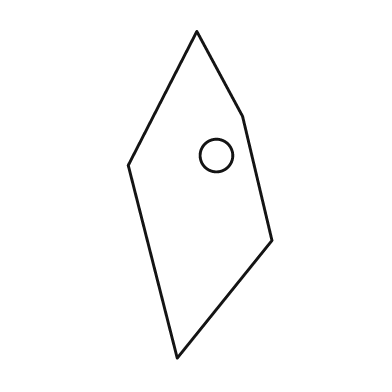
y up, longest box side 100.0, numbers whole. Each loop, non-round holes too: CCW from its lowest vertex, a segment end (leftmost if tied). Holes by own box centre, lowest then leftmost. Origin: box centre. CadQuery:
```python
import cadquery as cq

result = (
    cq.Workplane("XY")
    .moveTo(-7.0, -50.0)
    .lineTo(22.0, -14.0)
    .lineTo(13.0, 24.0)
    .lineTo(-1.0, 50.0)
    .lineTo(-22.0, 9.0)
    .close()
    .moveTo(5.0, 12.0)
    .circle(5.0)
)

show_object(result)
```